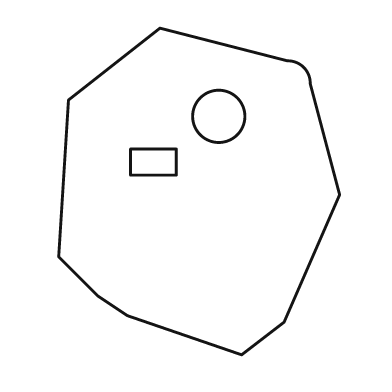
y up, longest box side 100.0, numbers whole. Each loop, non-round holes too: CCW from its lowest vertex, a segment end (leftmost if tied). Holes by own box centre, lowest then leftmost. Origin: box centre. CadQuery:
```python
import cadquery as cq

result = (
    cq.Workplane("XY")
    .moveTo(13.0, -50.0)
    .lineTo(26.0, -40.0)
    .lineTo(43.0, -1.0)
    .lineTo(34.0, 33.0)
    .threePointArc((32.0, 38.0), (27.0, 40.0))
    .lineTo(-12.0, 50.0)
    .lineTo(-40.0, 28.0)
    .lineTo(-43.0, -20.0)
    .lineTo(-31.0, -32.0)
    .lineTo(-22.0, -38.0)
    .close()
    .moveTo(-21.0, 5.0)
    .lineTo(-7.0, 5.0)
    .lineTo(-7.0, 13.0)
    .lineTo(-21.0, 13.0)
    .close()
    .moveTo(6.0, 23.0)
    .circle(8.0)
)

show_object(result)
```